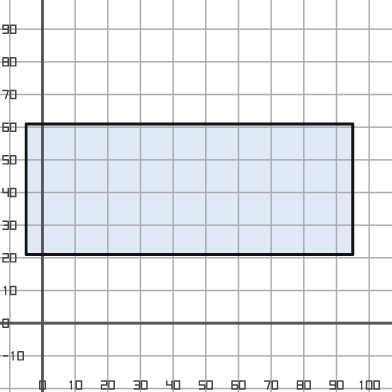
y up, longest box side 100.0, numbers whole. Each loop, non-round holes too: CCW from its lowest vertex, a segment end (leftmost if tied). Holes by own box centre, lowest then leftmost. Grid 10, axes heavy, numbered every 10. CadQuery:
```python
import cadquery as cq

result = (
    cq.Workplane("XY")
    .moveTo(-5.0, 21.0)
    .lineTo(95.0, 21.0)
    .lineTo(95.0, 61.0)
    .lineTo(-5.0, 61.0)
    .close()
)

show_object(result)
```